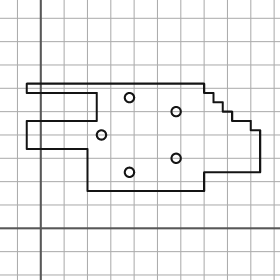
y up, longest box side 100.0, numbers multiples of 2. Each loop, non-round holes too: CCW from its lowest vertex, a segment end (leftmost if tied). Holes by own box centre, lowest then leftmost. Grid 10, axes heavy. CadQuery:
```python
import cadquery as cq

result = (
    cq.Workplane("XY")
    .moveTo(20.0, 16.0)
    .lineTo(70.0, 16.0)
    .lineTo(70.0, 24.0)
    .lineTo(94.0, 24.0)
    .lineTo(94.0, 42.0)
    .lineTo(90.0, 42.0)
    .lineTo(90.0, 46.0)
    .lineTo(82.0, 46.0)
    .lineTo(82.0, 50.0)
    .lineTo(78.0, 50.0)
    .lineTo(78.0, 54.0)
    .lineTo(74.0, 54.0)
    .lineTo(74.0, 58.0)
    .lineTo(70.0, 58.0)
    .lineTo(70.0, 62.0)
    .lineTo(-6.0, 62.0)
    .lineTo(-6.0, 58.0)
    .lineTo(24.0, 58.0)
    .lineTo(24.0, 46.0)
    .lineTo(-6.0, 46.0)
    .lineTo(-6.0, 34.0)
    .lineTo(20.0, 34.0)
    .close()
    .moveTo(38.0, 24.0)
    .circle(2.0)
    .moveTo(58.0, 30.0)
    .circle(2.0)
    .moveTo(26.0, 40.0)
    .circle(2.0)
    .moveTo(58.0, 50.0)
    .circle(2.0)
    .moveTo(38.0, 56.0)
    .circle(2.0)
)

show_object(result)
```